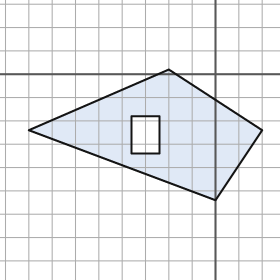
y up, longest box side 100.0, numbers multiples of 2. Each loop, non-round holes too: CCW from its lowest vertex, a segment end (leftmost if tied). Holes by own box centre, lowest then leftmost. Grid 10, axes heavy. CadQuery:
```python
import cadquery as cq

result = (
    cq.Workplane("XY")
    .moveTo(0.0, -54.0)
    .lineTo(20.0, -24.0)
    .lineTo(-20.0, 2.0)
    .lineTo(-80.0, -24.0)
    .close()
    .moveTo(-36.0, -34.0)
    .lineTo(-24.0, -34.0)
    .lineTo(-24.0, -18.0)
    .lineTo(-36.0, -18.0)
    .close()
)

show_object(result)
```